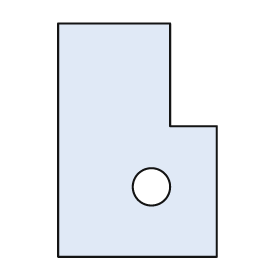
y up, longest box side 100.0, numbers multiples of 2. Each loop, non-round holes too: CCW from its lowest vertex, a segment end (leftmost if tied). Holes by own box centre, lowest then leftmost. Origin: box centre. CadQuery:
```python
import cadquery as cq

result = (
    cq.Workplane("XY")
    .moveTo(-34.0, -50.0)
    .lineTo(34.0, -50.0)
    .lineTo(34.0, 6.0)
    .lineTo(14.0, 6.0)
    .lineTo(14.0, 50.0)
    .lineTo(-34.0, 50.0)
    .close()
    .moveTo(6.0, -20.0)
    .circle(8.0)
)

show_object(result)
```